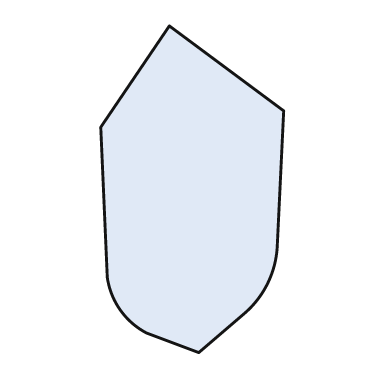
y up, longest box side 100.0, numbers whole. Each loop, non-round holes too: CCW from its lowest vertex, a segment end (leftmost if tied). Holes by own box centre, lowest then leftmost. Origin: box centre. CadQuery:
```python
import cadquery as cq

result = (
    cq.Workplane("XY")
    .moveTo(2.0, -50.0)
    .lineTo(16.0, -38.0)
    .threePointArc((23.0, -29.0), (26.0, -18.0))
    .lineTo(28.0, 24.0)
    .lineTo(-7.0, 50.0)
    .lineTo(-28.0, 19.0)
    .lineTo(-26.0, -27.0)
    .threePointArc((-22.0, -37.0), (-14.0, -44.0))
    .close()
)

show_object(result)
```